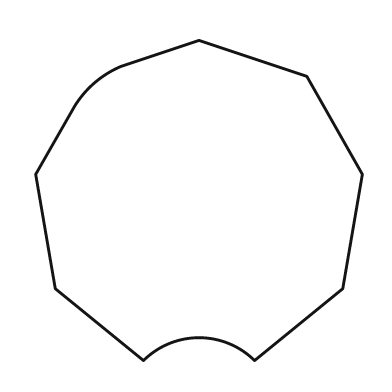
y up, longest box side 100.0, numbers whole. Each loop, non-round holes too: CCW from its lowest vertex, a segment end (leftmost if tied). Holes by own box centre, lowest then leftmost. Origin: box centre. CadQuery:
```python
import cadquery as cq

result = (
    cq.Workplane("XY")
    .moveTo(-17.0, -49.0)
    .threePointArc((0.0, -42.0), (17.0, -49.0))
    .lineTo(44.0, -27.0)
    .lineTo(50.0, 8.0)
    .lineTo(33.0, 38.0)
    .lineTo(0.0, 49.0)
    .lineTo(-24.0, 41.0)
    .threePointArc((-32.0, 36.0), (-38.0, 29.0))
    .lineTo(-50.0, 8.0)
    .lineTo(-44.0, -27.0)
    .close()
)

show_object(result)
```